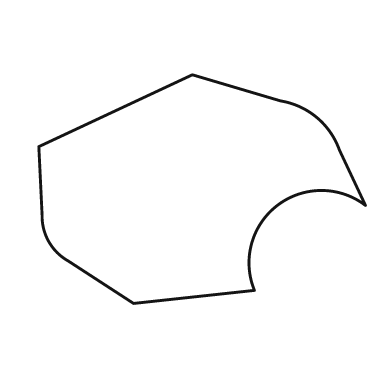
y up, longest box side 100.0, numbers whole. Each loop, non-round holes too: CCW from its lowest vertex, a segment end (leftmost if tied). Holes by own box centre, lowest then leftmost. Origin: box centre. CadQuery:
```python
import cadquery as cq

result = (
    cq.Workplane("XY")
    .moveTo(-21.0, -35.0)
    .lineTo(16.0, -31.0)
    .threePointArc((23.0, -5.0), (50.0, -5.0))
    .lineTo(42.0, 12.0)
    .threePointArc((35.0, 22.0), (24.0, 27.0))
    .lineTo(-3.0, 35.0)
    .lineTo(-50.0, 13.0)
    .lineTo(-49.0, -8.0)
    .threePointArc((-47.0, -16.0), (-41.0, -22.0))
    .close()
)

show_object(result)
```